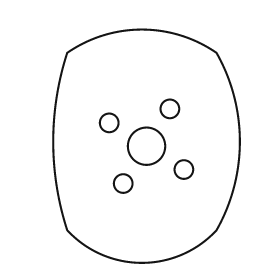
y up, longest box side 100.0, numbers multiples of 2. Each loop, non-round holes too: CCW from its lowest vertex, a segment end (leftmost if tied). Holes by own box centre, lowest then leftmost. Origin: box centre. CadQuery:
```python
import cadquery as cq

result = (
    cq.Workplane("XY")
    .moveTo(-34.0, -36.0)
    .threePointArc((-2.0, -50.0), (30.0, -36.0))
    .threePointArc((40.0, 2.0), (30.0, 40.0))
    .threePointArc((-2.0, 50.0), (-34.0, 40.0))
    .threePointArc((-40.0, 2.0), (-34.0, -36.0))
    .close()
    .moveTo(-10.0, -16.0)
    .circle(4.0)
    .moveTo(16.0, -10.0)
    .circle(4.0)
    .moveTo(0.0, 0.0)
    .circle(8.0)
    .moveTo(-16.0, 10.0)
    .circle(4.0)
    .moveTo(10.0, 16.0)
    .circle(4.0)
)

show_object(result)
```